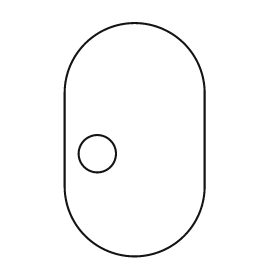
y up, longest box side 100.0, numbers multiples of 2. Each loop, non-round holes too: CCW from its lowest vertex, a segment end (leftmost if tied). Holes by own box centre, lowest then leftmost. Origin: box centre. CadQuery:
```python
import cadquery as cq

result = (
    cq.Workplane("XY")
    .moveTo(-30.0, -20.0)
    .threePointArc((0.0, -50.0), (30.0, -20.0))
    .lineTo(30.0, 20.0)
    .threePointArc((0.0, 50.0), (-30.0, 20.0))
    .close()
    .moveTo(-16.0, -6.0)
    .circle(8.0)
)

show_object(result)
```